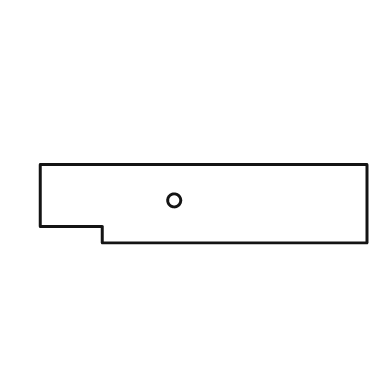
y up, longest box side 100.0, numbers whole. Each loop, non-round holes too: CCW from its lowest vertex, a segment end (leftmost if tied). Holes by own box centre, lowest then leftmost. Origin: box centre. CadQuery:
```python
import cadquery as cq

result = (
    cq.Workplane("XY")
    .moveTo(-31.0, -12.0)
    .lineTo(50.0, -12.0)
    .lineTo(50.0, 12.0)
    .lineTo(-50.0, 12.0)
    .lineTo(-50.0, -7.0)
    .lineTo(-31.0, -7.0)
    .close()
    .moveTo(-9.0, 1.0)
    .circle(2.0)
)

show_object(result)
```